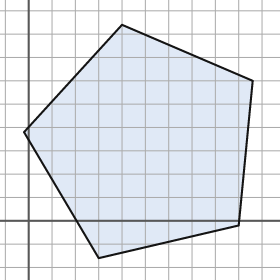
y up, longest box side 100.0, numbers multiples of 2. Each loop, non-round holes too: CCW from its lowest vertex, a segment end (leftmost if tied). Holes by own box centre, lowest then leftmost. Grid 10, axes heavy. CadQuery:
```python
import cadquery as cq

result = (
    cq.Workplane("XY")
    .moveTo(30.0, -16.0)
    .lineTo(90.0, -2.0)
    .lineTo(96.0, 60.0)
    .lineTo(40.0, 84.0)
    .lineTo(-2.0, 38.0)
    .close()
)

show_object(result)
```